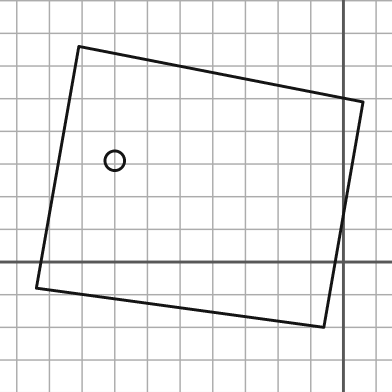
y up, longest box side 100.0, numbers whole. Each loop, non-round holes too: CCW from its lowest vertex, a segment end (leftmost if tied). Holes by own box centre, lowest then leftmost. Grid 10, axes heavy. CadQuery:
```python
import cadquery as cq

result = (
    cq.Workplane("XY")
    .moveTo(-6.0, -20.0)
    .lineTo(6.0, 49.0)
    .lineTo(-81.0, 66.0)
    .lineTo(-94.0, -8.0)
    .close()
    .moveTo(-70.0, 31.0)
    .circle(3.0)
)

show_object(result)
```